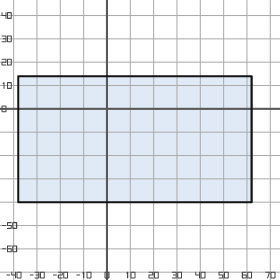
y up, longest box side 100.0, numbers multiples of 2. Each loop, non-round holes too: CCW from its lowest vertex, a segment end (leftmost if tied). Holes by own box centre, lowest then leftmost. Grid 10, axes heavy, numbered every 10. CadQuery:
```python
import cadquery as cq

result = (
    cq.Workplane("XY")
    .moveTo(-38.0, -40.0)
    .lineTo(62.0, -40.0)
    .lineTo(62.0, 14.0)
    .lineTo(-38.0, 14.0)
    .close()
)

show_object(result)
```